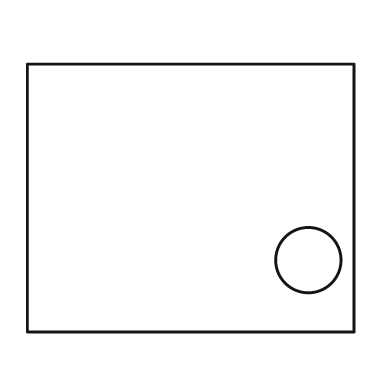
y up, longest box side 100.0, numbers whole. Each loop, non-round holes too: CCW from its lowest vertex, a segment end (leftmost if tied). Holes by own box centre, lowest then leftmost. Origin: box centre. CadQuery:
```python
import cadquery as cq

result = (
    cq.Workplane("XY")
    .moveTo(-50.0, -41.0)
    .lineTo(50.0, -41.0)
    .lineTo(50.0, 41.0)
    .lineTo(-50.0, 41.0)
    .close()
    .moveTo(36.0, -19.0)
    .circle(10.0)
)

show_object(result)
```